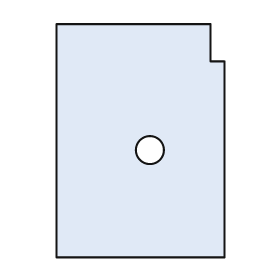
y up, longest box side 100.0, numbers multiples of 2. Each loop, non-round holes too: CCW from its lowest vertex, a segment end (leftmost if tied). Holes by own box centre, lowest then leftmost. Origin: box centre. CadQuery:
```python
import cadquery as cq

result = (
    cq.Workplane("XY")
    .moveTo(-36.0, -50.0)
    .lineTo(36.0, -50.0)
    .lineTo(36.0, 34.0)
    .lineTo(30.0, 34.0)
    .lineTo(30.0, 50.0)
    .lineTo(-36.0, 50.0)
    .close()
    .moveTo(4.0, -4.0)
    .circle(6.0)
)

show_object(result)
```